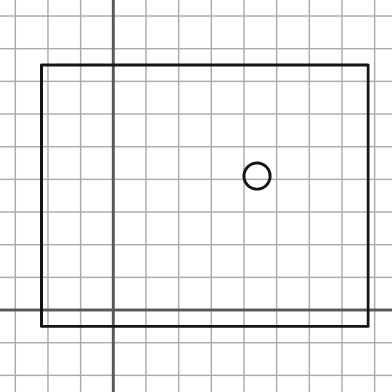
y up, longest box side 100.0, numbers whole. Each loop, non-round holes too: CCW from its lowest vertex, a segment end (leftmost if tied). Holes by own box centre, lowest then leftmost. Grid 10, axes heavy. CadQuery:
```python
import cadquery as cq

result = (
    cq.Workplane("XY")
    .moveTo(-22.0, -5.0)
    .lineTo(78.0, -5.0)
    .lineTo(78.0, 75.0)
    .lineTo(-22.0, 75.0)
    .close()
    .moveTo(44.0, 41.0)
    .circle(4.0)
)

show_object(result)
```